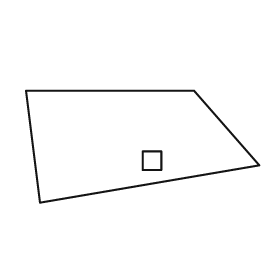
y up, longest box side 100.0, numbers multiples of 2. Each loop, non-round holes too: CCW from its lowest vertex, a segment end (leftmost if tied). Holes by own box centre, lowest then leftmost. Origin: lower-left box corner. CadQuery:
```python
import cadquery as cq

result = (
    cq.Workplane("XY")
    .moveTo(6.0, 0.0)
    .lineTo(100.0, 16.0)
    .lineTo(72.0, 48.0)
    .lineTo(0.0, 48.0)
    .close()
    .moveTo(50.0, 14.0)
    .lineTo(58.0, 14.0)
    .lineTo(58.0, 22.0)
    .lineTo(50.0, 22.0)
    .close()
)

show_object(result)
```